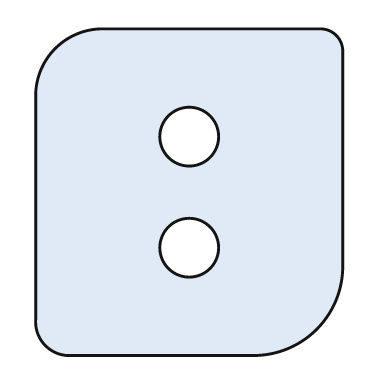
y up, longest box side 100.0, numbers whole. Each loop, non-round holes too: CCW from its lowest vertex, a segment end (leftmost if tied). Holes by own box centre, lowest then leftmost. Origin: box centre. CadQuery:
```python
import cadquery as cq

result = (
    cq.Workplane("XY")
    .moveTo(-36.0, -50.0)
    .lineTo(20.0, -50.0)
    .threePointArc((39.0, -42.0), (47.0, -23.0))
    .lineTo(47.0, 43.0)
    .threePointArc((45.0, 48.0), (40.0, 50.0))
    .lineTo(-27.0, 50.0)
    .threePointArc((-41.0, 44.0), (-47.0, 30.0))
    .lineTo(-47.0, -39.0)
    .threePointArc((-44.0, -47.0), (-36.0, -50.0))
    .close()
    .moveTo(0.0, -17.0)
    .circle(9.0)
    .moveTo(0.0, 17.0)
    .circle(9.0)
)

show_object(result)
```